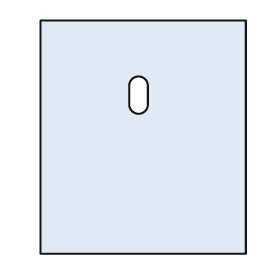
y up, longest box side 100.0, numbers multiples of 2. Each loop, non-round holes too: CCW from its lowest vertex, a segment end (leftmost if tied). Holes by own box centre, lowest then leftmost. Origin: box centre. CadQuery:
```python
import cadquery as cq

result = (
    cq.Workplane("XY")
    .moveTo(-44.0, -50.0)
    .lineTo(44.0, -50.0)
    .lineTo(44.0, 50.0)
    .lineTo(-44.0, 50.0)
    .close()
    .moveTo(-6.0, 14.0)
    .threePointArc((-2.0, 10.0), (2.0, 14.0))
    .lineTo(2.0, 22.0)
    .threePointArc((-2.0, 26.0), (-6.0, 22.0))
    .close()
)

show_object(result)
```